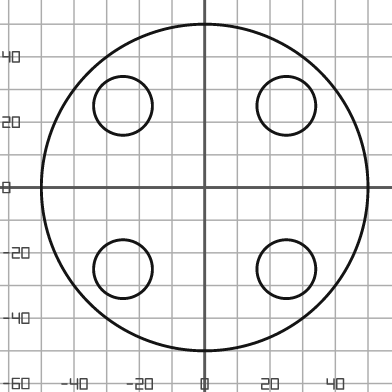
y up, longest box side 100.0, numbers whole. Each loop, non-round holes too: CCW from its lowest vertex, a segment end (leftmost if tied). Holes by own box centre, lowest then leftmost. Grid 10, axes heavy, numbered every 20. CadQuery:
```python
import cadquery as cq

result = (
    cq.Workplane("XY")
    .moveTo(0.0, 0.0)
    .circle(50.0)
    .moveTo(-25.0, -25.0)
    .circle(9.0)
    .moveTo(25.0, -25.0)
    .circle(9.0)
    .moveTo(-25.0, 25.0)
    .circle(9.0)
    .moveTo(25.0, 25.0)
    .circle(9.0)
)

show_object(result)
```